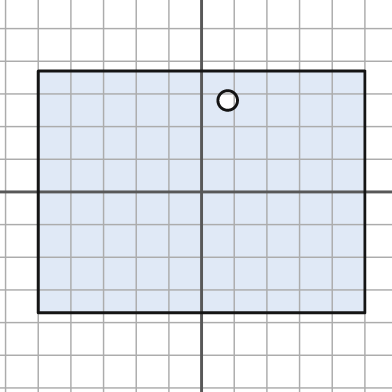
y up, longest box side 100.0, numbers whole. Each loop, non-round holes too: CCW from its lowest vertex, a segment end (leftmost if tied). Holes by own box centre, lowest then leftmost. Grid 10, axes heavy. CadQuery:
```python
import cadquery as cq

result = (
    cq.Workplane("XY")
    .moveTo(-50.0, -37.0)
    .lineTo(50.0, -37.0)
    .lineTo(50.0, 37.0)
    .lineTo(-50.0, 37.0)
    .close()
    .moveTo(8.0, 28.0)
    .circle(3.0)
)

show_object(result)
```